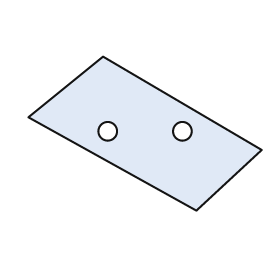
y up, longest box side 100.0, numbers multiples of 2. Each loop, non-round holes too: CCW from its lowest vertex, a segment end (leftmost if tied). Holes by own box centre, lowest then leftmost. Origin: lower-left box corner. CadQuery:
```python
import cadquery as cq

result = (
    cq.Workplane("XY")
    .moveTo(72.0, 0.0)
    .lineTo(100.0, 26.0)
    .lineTo(32.0, 66.0)
    .lineTo(0.0, 40.0)
    .close()
    .moveTo(34.0, 34.0)
    .circle(4.0)
    .moveTo(66.0, 34.0)
    .circle(4.0)
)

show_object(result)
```